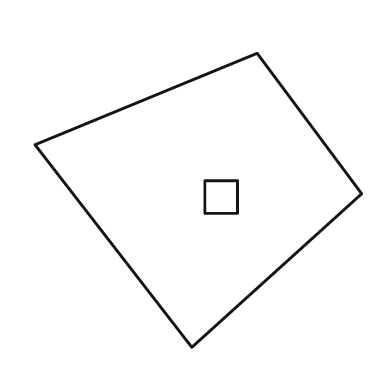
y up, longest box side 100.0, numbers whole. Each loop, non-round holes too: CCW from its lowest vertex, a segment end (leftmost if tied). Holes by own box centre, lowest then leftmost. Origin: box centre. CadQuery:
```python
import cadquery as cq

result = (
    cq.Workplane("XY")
    .moveTo(-2.0, -45.0)
    .lineTo(50.0, 2.0)
    .lineTo(18.0, 45.0)
    .lineTo(-50.0, 17.0)
    .close()
    .moveTo(2.0, -4.0)
    .lineTo(12.0, -4.0)
    .lineTo(12.0, 6.0)
    .lineTo(2.0, 6.0)
    .close()
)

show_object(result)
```